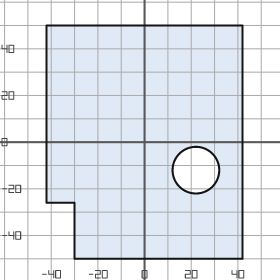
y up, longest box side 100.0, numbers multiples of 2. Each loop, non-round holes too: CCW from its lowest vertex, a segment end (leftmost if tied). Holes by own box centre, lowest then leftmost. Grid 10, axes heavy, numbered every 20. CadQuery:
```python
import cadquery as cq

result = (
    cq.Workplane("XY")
    .moveTo(-30.0, -50.0)
    .lineTo(42.0, -50.0)
    .lineTo(42.0, 50.0)
    .lineTo(-42.0, 50.0)
    .lineTo(-42.0, -26.0)
    .lineTo(-30.0, -26.0)
    .close()
    .moveTo(22.0, -12.0)
    .circle(10.0)
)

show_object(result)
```